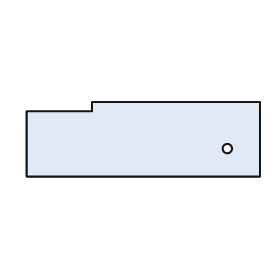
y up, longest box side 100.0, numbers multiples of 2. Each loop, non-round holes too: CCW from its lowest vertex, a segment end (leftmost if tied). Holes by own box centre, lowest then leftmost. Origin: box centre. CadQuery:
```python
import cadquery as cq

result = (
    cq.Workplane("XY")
    .moveTo(-50.0, -16.0)
    .lineTo(50.0, -16.0)
    .lineTo(50.0, 16.0)
    .lineTo(-22.0, 16.0)
    .lineTo(-22.0, 12.0)
    .lineTo(-50.0, 12.0)
    .close()
    .moveTo(36.0, -4.0)
    .circle(2.0)
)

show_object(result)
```